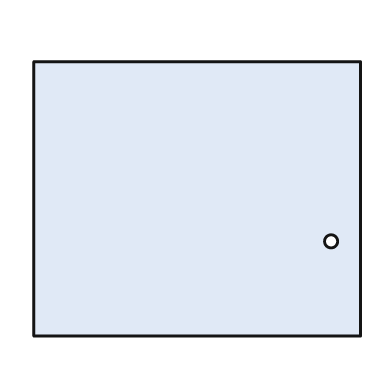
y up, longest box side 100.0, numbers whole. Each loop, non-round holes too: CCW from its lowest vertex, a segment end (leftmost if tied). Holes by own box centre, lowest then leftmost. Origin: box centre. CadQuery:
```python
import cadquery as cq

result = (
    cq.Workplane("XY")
    .moveTo(-50.0, -42.0)
    .lineTo(50.0, -42.0)
    .lineTo(50.0, 42.0)
    .lineTo(-50.0, 42.0)
    .close()
    .moveTo(41.0, -13.0)
    .circle(2.0)
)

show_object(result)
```